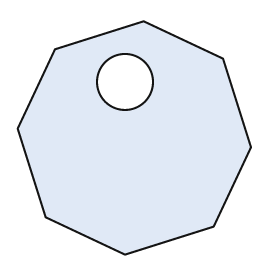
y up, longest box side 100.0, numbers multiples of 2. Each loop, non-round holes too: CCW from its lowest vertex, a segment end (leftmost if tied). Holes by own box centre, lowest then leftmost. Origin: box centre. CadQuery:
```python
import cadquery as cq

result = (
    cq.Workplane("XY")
    .moveTo(-4.0, -50.0)
    .lineTo(34.0, -38.0)
    .lineTo(50.0, -4.0)
    .lineTo(38.0, 34.0)
    .lineTo(4.0, 50.0)
    .lineTo(-34.0, 38.0)
    .lineTo(-50.0, 4.0)
    .lineTo(-38.0, -34.0)
    .close()
    .moveTo(-4.0, 24.0)
    .circle(12.0)
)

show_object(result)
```